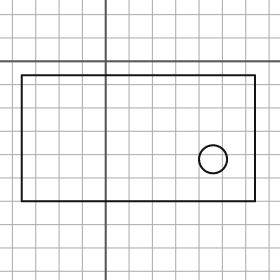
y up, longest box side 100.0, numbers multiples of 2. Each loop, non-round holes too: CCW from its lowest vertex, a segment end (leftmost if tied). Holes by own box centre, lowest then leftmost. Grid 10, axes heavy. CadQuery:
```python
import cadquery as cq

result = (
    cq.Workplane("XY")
    .moveTo(-36.0, -60.0)
    .lineTo(64.0, -60.0)
    .lineTo(64.0, -6.0)
    .lineTo(-36.0, -6.0)
    .close()
    .moveTo(46.0, -42.0)
    .circle(6.0)
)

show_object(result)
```